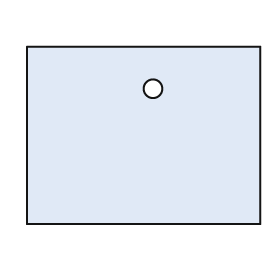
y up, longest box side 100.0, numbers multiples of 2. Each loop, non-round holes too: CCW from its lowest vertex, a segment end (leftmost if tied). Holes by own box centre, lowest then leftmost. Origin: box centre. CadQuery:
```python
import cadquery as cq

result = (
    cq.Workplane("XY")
    .moveTo(-50.0, -38.0)
    .lineTo(50.0, -38.0)
    .lineTo(50.0, 38.0)
    .lineTo(-50.0, 38.0)
    .close()
    .moveTo(4.0, 20.0)
    .circle(4.0)
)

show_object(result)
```